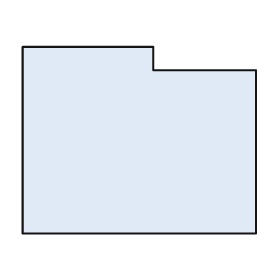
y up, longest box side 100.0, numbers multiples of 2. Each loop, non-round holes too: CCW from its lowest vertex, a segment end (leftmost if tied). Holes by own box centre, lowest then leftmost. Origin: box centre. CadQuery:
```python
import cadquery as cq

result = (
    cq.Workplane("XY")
    .moveTo(-50.0, -40.0)
    .lineTo(50.0, -40.0)
    .lineTo(50.0, 30.0)
    .lineTo(6.0, 30.0)
    .lineTo(6.0, 40.0)
    .lineTo(-50.0, 40.0)
    .close()
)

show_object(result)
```